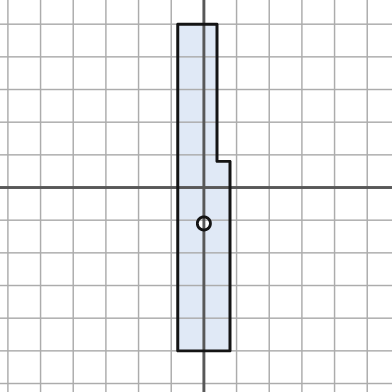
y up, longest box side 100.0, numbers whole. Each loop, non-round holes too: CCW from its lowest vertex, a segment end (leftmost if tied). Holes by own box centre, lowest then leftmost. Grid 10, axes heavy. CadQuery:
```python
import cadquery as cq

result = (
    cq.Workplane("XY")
    .moveTo(-8.0, -50.0)
    .lineTo(8.0, -50.0)
    .lineTo(8.0, 8.0)
    .lineTo(4.0, 8.0)
    .lineTo(4.0, 50.0)
    .lineTo(-8.0, 50.0)
    .close()
    .moveTo(0.0, -11.0)
    .circle(2.0)
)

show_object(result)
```